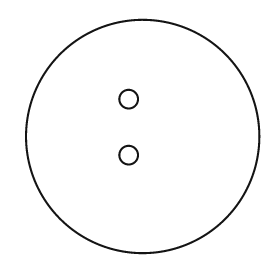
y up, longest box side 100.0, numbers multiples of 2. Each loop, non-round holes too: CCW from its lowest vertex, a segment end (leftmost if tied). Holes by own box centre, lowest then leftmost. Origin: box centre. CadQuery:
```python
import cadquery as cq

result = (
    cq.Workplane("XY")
    .moveTo(0.0, 0.0)
    .circle(50.0)
    .moveTo(-6.0, -8.0)
    .circle(4.0)
    .moveTo(-6.0, 16.0)
    .circle(4.0)
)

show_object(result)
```